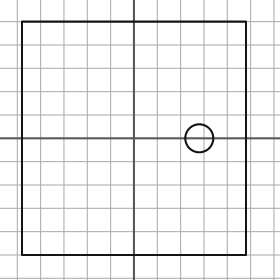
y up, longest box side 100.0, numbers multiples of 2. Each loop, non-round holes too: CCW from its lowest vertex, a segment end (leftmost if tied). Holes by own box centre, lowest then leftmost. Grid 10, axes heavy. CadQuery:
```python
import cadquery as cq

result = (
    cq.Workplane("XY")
    .moveTo(-48.0, -50.0)
    .lineTo(48.0, -50.0)
    .lineTo(48.0, 50.0)
    .lineTo(-48.0, 50.0)
    .close()
    .moveTo(28.0, 0.0)
    .circle(6.0)
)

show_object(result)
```